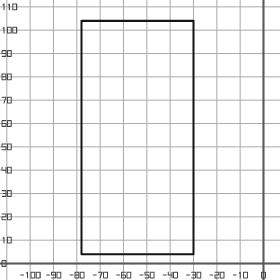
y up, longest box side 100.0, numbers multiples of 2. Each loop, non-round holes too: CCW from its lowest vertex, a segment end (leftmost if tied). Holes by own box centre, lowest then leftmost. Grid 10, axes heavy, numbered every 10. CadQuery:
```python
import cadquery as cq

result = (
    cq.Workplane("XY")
    .moveTo(-78.0, 4.0)
    .lineTo(-30.0, 4.0)
    .lineTo(-30.0, 104.0)
    .lineTo(-78.0, 104.0)
    .close()
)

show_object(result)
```